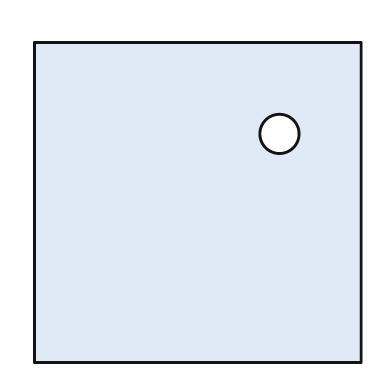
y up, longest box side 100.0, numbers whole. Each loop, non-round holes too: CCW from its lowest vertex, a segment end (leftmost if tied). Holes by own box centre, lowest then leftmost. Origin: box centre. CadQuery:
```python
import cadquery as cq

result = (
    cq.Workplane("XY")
    .moveTo(-50.0, -49.0)
    .lineTo(50.0, -49.0)
    .lineTo(50.0, 49.0)
    .lineTo(-50.0, 49.0)
    .close()
    .moveTo(25.0, 21.0)
    .circle(6.0)
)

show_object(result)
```